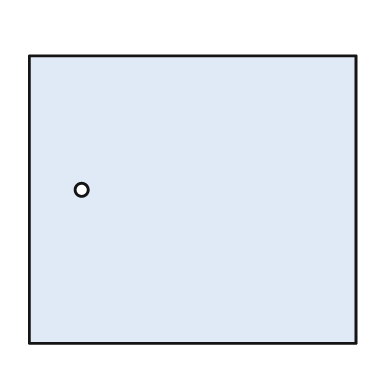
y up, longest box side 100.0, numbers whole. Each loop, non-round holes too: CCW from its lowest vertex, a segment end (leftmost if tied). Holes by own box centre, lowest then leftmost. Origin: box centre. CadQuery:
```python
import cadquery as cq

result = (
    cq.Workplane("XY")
    .moveTo(-50.0, -44.0)
    .lineTo(50.0, -44.0)
    .lineTo(50.0, 44.0)
    .lineTo(-50.0, 44.0)
    .close()
    .moveTo(-34.0, 3.0)
    .circle(2.0)
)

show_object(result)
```